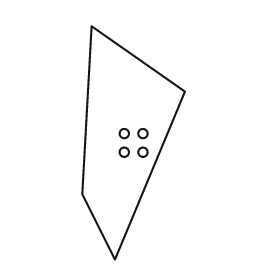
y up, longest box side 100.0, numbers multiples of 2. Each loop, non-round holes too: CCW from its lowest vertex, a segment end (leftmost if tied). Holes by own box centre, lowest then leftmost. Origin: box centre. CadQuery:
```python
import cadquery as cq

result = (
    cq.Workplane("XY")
    .moveTo(-8.0, -50.0)
    .lineTo(22.0, 22.0)
    .lineTo(-18.0, 50.0)
    .lineTo(-22.0, -22.0)
    .close()
    .moveTo(-4.0, -4.0)
    .circle(2.0)
    .moveTo(4.0, -4.0)
    .circle(2.0)
    .moveTo(-4.0, 4.0)
    .circle(2.0)
    .moveTo(4.0, 4.0)
    .circle(2.0)
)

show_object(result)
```